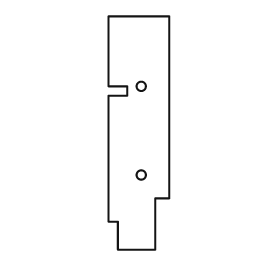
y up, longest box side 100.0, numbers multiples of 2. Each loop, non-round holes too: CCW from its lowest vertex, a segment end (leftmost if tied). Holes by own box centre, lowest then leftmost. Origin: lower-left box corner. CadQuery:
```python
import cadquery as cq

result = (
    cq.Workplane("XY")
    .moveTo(4.0, 0.0)
    .lineTo(20.0, 0.0)
    .lineTo(20.0, 22.0)
    .lineTo(26.0, 22.0)
    .lineTo(26.0, 100.0)
    .lineTo(0.0, 100.0)
    .lineTo(0.0, 70.0)
    .lineTo(8.0, 70.0)
    .lineTo(8.0, 66.0)
    .lineTo(0.0, 66.0)
    .lineTo(0.0, 12.0)
    .lineTo(4.0, 12.0)
    .close()
    .moveTo(14.0, 32.0)
    .circle(2.0)
    .moveTo(14.0, 70.0)
    .circle(2.0)
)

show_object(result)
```